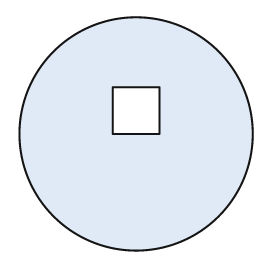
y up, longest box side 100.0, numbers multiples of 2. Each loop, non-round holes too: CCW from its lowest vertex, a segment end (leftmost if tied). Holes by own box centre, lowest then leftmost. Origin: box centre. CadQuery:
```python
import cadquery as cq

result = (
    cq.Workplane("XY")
    .moveTo(0.0, 0.0)
    .circle(50.0)
    .moveTo(-10.0, 0.0)
    .lineTo(10.0, 0.0)
    .lineTo(10.0, 20.0)
    .lineTo(-10.0, 20.0)
    .close()
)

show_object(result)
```